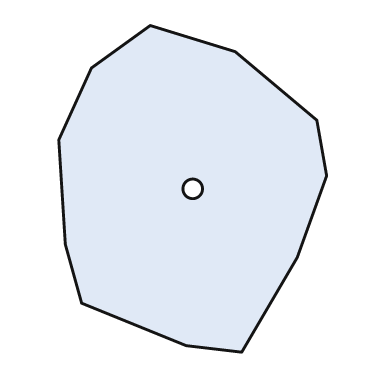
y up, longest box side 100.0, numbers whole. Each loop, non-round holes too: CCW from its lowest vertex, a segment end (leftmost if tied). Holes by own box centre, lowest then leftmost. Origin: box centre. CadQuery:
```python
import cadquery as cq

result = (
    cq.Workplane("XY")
    .moveTo(15.0, -50.0)
    .lineTo(32.0, -21.0)
    .lineTo(41.0, 4.0)
    .lineTo(38.0, 21.0)
    .lineTo(13.0, 42.0)
    .lineTo(-13.0, 50.0)
    .lineTo(-31.0, 37.0)
    .lineTo(-41.0, 15.0)
    .lineTo(-39.0, -17.0)
    .lineTo(-34.0, -35.0)
    .lineTo(-2.0, -48.0)
    .close()
    .moveTo(0.0, 0.0)
    .circle(3.0)
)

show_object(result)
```